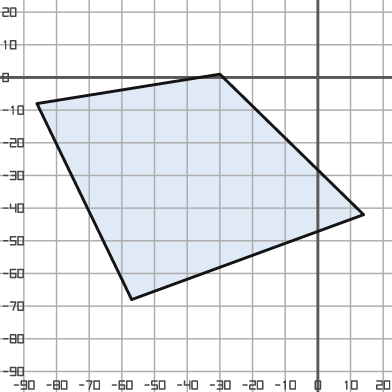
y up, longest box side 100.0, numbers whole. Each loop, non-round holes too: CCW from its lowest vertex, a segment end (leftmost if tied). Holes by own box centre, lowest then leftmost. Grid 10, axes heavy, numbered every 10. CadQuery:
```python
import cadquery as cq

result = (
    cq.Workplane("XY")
    .moveTo(-57.0, -68.0)
    .lineTo(14.0, -42.0)
    .lineTo(-30.0, 1.0)
    .lineTo(-86.0, -8.0)
    .close()
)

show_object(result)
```